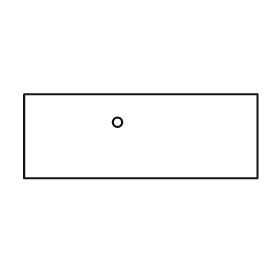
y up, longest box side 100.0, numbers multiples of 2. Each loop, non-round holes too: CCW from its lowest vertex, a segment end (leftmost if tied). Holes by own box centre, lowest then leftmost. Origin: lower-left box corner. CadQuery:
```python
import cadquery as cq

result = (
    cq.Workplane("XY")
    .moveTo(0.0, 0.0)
    .lineTo(100.0, 0.0)
    .lineTo(100.0, 36.0)
    .lineTo(0.0, 36.0)
    .close()
    .moveTo(40.0, 24.0)
    .circle(2.0)
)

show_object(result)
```